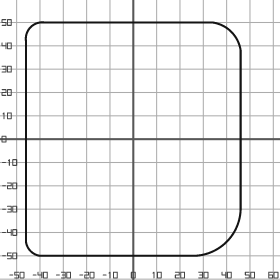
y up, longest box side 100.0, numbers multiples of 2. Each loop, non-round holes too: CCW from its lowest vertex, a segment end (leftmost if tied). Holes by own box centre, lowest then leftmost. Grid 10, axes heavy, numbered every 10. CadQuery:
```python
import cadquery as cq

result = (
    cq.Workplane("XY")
    .moveTo(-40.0, -50.0)
    .lineTo(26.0, -50.0)
    .threePointArc((40.0, -44.0), (46.0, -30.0))
    .lineTo(46.0, 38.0)
    .threePointArc((42.0, 46.0), (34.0, 50.0))
    .lineTo(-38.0, 50.0)
    .threePointArc((-44.0, 48.0), (-46.0, 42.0))
    .lineTo(-46.0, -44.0)
    .threePointArc((-44.0, -48.0), (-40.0, -50.0))
    .close()
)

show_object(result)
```